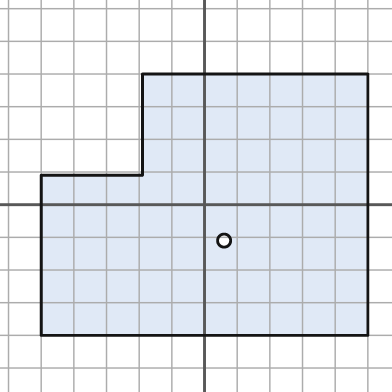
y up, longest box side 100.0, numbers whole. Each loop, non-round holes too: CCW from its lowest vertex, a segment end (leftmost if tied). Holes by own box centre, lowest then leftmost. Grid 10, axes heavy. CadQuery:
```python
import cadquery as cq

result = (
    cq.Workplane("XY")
    .moveTo(-50.0, -40.0)
    .lineTo(50.0, -40.0)
    .lineTo(50.0, 40.0)
    .lineTo(-19.0, 40.0)
    .lineTo(-19.0, 9.0)
    .lineTo(-50.0, 9.0)
    .close()
    .moveTo(6.0, -11.0)
    .circle(2.0)
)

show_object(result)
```